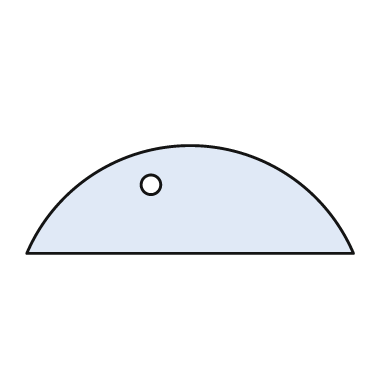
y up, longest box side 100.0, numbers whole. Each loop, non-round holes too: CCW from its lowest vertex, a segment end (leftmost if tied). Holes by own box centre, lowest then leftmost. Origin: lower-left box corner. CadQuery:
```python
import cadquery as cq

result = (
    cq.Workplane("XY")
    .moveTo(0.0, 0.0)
    .lineTo(100.0, 0.0)
    .threePointArc((50.0, 33.0), (0.0, 0.0))
    .close()
    .moveTo(38.0, 21.0)
    .circle(3.0)
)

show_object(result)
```